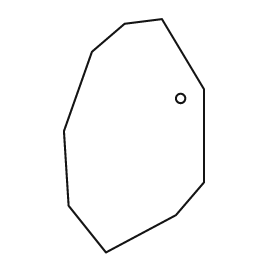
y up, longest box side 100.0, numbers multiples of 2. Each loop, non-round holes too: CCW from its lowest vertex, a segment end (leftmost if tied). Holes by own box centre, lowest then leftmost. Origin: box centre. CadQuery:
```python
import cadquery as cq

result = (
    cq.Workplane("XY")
    .moveTo(-12.0, -50.0)
    .lineTo(18.0, -34.0)
    .lineTo(30.0, -20.0)
    .lineTo(30.0, 20.0)
    .lineTo(12.0, 50.0)
    .lineTo(-4.0, 48.0)
    .lineTo(-18.0, 36.0)
    .lineTo(-30.0, 2.0)
    .lineTo(-28.0, -30.0)
    .close()
    .moveTo(20.0, 16.0)
    .circle(2.0)
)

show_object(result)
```